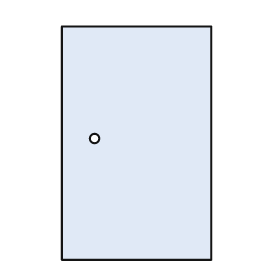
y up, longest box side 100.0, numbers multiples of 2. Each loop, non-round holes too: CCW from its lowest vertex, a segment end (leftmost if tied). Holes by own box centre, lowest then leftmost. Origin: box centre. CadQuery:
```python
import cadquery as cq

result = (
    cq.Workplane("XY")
    .moveTo(-32.0, -50.0)
    .lineTo(32.0, -50.0)
    .lineTo(32.0, 50.0)
    .lineTo(-32.0, 50.0)
    .close()
    .moveTo(-18.0, 2.0)
    .circle(2.0)
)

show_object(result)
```